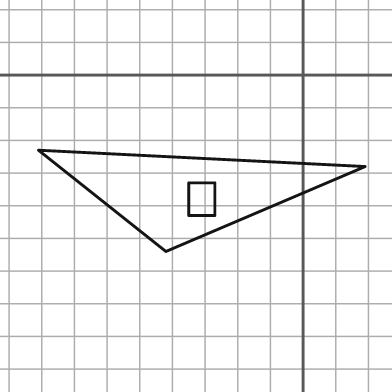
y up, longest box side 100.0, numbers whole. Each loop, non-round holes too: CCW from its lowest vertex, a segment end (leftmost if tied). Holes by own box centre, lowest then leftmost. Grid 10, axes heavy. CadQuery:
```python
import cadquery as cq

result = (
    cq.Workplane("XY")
    .moveTo(-42.0, -54.0)
    .lineTo(19.0, -28.0)
    .lineTo(-81.0, -23.0)
    .close()
    .moveTo(-35.0, -43.0)
    .lineTo(-27.0, -43.0)
    .lineTo(-27.0, -33.0)
    .lineTo(-35.0, -33.0)
    .close()
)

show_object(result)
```